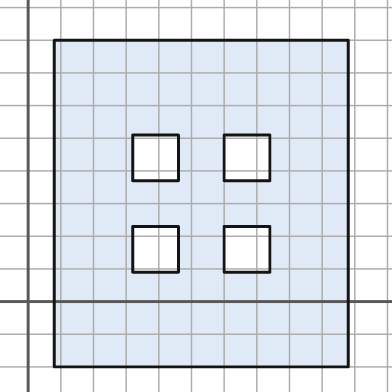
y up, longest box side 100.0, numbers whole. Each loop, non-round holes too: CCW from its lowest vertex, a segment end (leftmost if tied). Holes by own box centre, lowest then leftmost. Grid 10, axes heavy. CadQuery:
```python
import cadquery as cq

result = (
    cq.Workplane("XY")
    .moveTo(8.0, -20.0)
    .lineTo(98.0, -20.0)
    .lineTo(98.0, 80.0)
    .lineTo(8.0, 80.0)
    .close()
    .moveTo(32.0, 9.0)
    .lineTo(46.0, 9.0)
    .lineTo(46.0, 23.0)
    .lineTo(32.0, 23.0)
    .close()
    .moveTo(60.0, 9.0)
    .lineTo(74.0, 9.0)
    .lineTo(74.0, 23.0)
    .lineTo(60.0, 23.0)
    .close()
    .moveTo(32.0, 37.0)
    .lineTo(46.0, 37.0)
    .lineTo(46.0, 51.0)
    .lineTo(32.0, 51.0)
    .close()
    .moveTo(60.0, 37.0)
    .lineTo(74.0, 37.0)
    .lineTo(74.0, 51.0)
    .lineTo(60.0, 51.0)
    .close()
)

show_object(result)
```